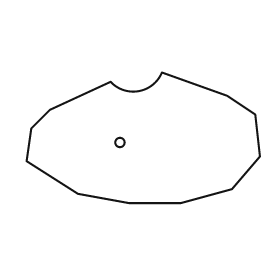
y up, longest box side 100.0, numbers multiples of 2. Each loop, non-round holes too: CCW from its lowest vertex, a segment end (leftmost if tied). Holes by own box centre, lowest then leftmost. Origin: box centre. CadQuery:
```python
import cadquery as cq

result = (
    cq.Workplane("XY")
    .moveTo(-6.0, -28.0)
    .lineTo(16.0, -28.0)
    .lineTo(38.0, -22.0)
    .lineTo(50.0, -8.0)
    .lineTo(48.0, 10.0)
    .lineTo(36.0, 18.0)
    .lineTo(8.0, 28.0)
    .threePointArc((-2.0, 20.0), (-14.0, 24.0))
    .lineTo(-40.0, 12.0)
    .lineTo(-48.0, 4.0)
    .lineTo(-50.0, -10.0)
    .lineTo(-28.0, -24.0)
    .close()
    .moveTo(-10.0, -2.0)
    .circle(2.0)
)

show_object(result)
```